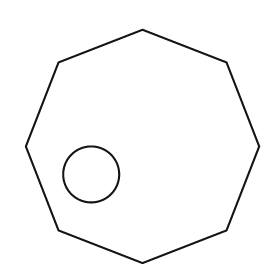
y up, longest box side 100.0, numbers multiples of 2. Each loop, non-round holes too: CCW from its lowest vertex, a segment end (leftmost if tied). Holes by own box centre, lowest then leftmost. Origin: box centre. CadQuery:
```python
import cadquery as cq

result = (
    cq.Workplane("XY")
    .moveTo(0.0, -50.0)
    .lineTo(36.0, -36.0)
    .lineTo(50.0, 0.0)
    .lineTo(36.0, 36.0)
    .lineTo(0.0, 50.0)
    .lineTo(-36.0, 36.0)
    .lineTo(-50.0, 0.0)
    .lineTo(-36.0, -36.0)
    .close()
    .moveTo(-22.0, -12.0)
    .circle(12.0)
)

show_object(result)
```